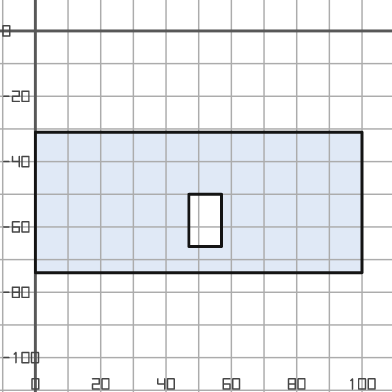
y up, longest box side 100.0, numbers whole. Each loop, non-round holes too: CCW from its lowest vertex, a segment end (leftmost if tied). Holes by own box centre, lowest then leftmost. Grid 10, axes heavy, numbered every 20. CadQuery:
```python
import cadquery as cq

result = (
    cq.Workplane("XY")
    .moveTo(0.0, -74.0)
    .lineTo(100.0, -74.0)
    .lineTo(100.0, -31.0)
    .lineTo(0.0, -31.0)
    .close()
    .moveTo(47.0, -66.0)
    .lineTo(57.0, -66.0)
    .lineTo(57.0, -50.0)
    .lineTo(47.0, -50.0)
    .close()
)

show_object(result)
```